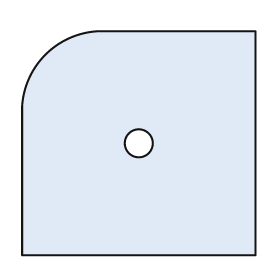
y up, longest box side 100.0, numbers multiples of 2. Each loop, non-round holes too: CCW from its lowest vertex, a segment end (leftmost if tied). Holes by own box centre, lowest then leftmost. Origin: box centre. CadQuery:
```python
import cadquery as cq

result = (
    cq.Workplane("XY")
    .moveTo(-50.0, -48.0)
    .lineTo(50.0, -48.0)
    .lineTo(50.0, 48.0)
    .lineTo(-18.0, 48.0)
    .threePointArc((-40.0, 38.0), (-50.0, 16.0))
    .close()
    .moveTo(0.0, 0.0)
    .circle(6.0)
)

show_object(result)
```